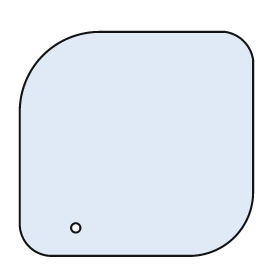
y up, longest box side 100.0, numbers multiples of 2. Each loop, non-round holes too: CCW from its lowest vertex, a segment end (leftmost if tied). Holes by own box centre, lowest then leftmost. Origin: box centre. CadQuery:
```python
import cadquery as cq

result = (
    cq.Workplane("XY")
    .moveTo(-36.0, -48.0)
    .lineTo(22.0, -48.0)
    .threePointArc((42.0, -40.0), (50.0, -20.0))
    .lineTo(50.0, 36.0)
    .threePointArc((46.0, 44.0), (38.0, 48.0))
    .lineTo(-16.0, 48.0)
    .threePointArc((-40.0, 38.0), (-50.0, 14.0))
    .lineTo(-50.0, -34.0)
    .threePointArc((-46.0, -44.0), (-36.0, -48.0))
    .close()
    .moveTo(-26.0, -36.0)
    .circle(2.0)
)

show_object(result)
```